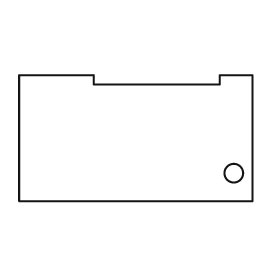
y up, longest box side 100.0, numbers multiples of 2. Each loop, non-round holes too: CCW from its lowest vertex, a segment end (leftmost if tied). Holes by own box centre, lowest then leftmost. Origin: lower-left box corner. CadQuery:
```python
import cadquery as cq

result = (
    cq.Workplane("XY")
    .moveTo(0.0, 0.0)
    .lineTo(100.0, 0.0)
    .lineTo(100.0, 54.0)
    .lineTo(86.0, 54.0)
    .lineTo(86.0, 50.0)
    .lineTo(32.0, 50.0)
    .lineTo(32.0, 54.0)
    .lineTo(0.0, 54.0)
    .close()
    .moveTo(92.0, 12.0)
    .circle(4.0)
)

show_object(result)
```